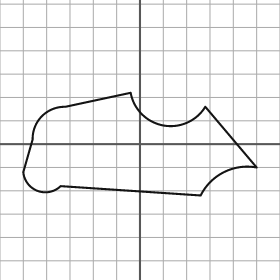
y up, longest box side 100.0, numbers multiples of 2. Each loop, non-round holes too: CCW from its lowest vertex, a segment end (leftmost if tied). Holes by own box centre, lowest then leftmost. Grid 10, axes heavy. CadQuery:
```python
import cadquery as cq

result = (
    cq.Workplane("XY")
    .moveTo(26.0, -22.0)
    .threePointArc((36.0, -12.0), (50.0, -10.0))
    .lineTo(28.0, 16.0)
    .threePointArc((10.0, 8.0), (-4.0, 22.0))
    .lineTo(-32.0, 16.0)
    .threePointArc((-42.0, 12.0), (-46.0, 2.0))
    .lineTo(-50.0, -12.0)
    .threePointArc((-44.0, -20.0), (-34.0, -18.0))
    .close()
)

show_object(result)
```